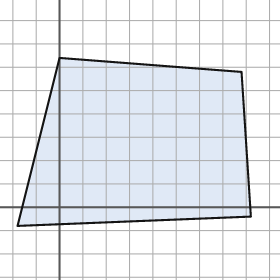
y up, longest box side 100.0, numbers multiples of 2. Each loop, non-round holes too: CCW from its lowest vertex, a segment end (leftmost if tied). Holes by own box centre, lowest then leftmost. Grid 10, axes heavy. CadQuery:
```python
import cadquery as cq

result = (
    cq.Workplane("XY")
    .moveTo(-18.0, -8.0)
    .lineTo(82.0, -4.0)
    .lineTo(78.0, 58.0)
    .lineTo(0.0, 64.0)
    .close()
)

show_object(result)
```